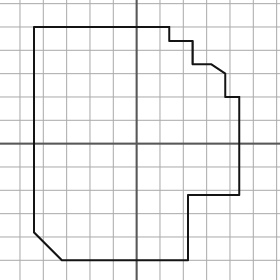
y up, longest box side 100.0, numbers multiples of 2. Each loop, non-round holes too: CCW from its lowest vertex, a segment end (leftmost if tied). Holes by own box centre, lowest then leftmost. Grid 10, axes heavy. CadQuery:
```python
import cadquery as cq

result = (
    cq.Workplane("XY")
    .moveTo(-32.0, -50.0)
    .lineTo(22.0, -50.0)
    .lineTo(22.0, -22.0)
    .lineTo(44.0, -22.0)
    .lineTo(44.0, 20.0)
    .lineTo(38.0, 20.0)
    .lineTo(38.0, 30.0)
    .lineTo(32.0, 34.0)
    .lineTo(24.0, 34.0)
    .lineTo(24.0, 44.0)
    .lineTo(14.0, 44.0)
    .lineTo(14.0, 50.0)
    .lineTo(-44.0, 50.0)
    .lineTo(-44.0, -38.0)
    .close()
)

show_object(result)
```